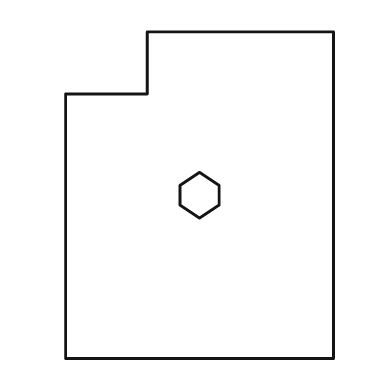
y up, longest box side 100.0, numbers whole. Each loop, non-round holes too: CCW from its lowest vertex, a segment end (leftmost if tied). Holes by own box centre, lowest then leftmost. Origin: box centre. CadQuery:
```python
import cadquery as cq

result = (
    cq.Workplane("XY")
    .moveTo(-41.0, -50.0)
    .lineTo(41.0, -50.0)
    .lineTo(41.0, 50.0)
    .lineTo(-16.0, 50.0)
    .lineTo(-16.0, 31.0)
    .lineTo(-41.0, 31.0)
    .close()
    .moveTo(0.0, -7.0)
    .lineTo(6.0, -3.0)
    .lineTo(6.0, 3.0)
    .lineTo(0.0, 7.0)
    .lineTo(-6.0, 3.0)
    .lineTo(-6.0, -3.0)
    .close()
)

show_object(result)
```